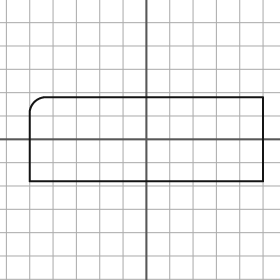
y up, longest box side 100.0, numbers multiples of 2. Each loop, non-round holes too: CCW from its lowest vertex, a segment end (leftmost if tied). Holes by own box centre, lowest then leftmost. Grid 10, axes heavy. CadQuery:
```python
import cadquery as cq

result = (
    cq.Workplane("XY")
    .moveTo(-50.0, -18.0)
    .lineTo(50.0, -18.0)
    .lineTo(50.0, 18.0)
    .lineTo(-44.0, 18.0)
    .threePointArc((-48.0, 16.0), (-50.0, 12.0))
    .close()
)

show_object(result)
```